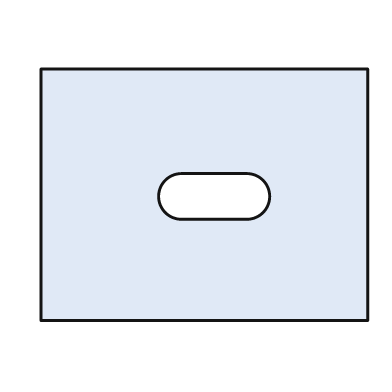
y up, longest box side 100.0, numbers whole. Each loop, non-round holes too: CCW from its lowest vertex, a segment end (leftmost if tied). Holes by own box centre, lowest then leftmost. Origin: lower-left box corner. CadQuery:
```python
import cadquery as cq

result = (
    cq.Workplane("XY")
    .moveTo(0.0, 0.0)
    .lineTo(100.0, 0.0)
    .lineTo(100.0, 77.0)
    .lineTo(0.0, 77.0)
    .close()
    .moveTo(43.0, 31.0)
    .lineTo(63.0, 31.0)
    .threePointArc((70.0, 38.0), (63.0, 45.0))
    .lineTo(43.0, 45.0)
    .threePointArc((36.0, 38.0), (43.0, 31.0))
    .close()
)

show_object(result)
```